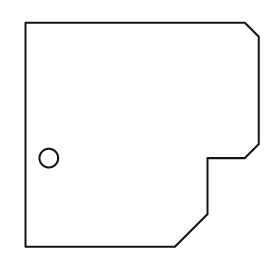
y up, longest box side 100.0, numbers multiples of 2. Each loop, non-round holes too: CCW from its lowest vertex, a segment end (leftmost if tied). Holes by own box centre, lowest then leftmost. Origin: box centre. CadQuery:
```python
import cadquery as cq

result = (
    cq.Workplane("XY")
    .moveTo(-50.0, -48.0)
    .lineTo(14.0, -48.0)
    .lineTo(28.0, -34.0)
    .lineTo(28.0, -10.0)
    .lineTo(44.0, -10.0)
    .lineTo(50.0, -4.0)
    .lineTo(50.0, 42.0)
    .lineTo(44.0, 48.0)
    .lineTo(-50.0, 48.0)
    .close()
    .moveTo(-40.0, -10.0)
    .circle(4.0)
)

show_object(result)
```